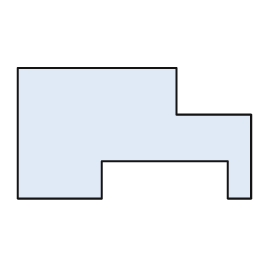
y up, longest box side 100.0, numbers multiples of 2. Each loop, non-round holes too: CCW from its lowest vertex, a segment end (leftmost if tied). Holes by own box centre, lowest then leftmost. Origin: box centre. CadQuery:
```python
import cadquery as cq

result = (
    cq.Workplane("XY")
    .moveTo(-50.0, -28.0)
    .lineTo(-14.0, -28.0)
    .lineTo(-14.0, -12.0)
    .lineTo(40.0, -12.0)
    .lineTo(40.0, -28.0)
    .lineTo(50.0, -28.0)
    .lineTo(50.0, 8.0)
    .lineTo(18.0, 8.0)
    .lineTo(18.0, 28.0)
    .lineTo(-50.0, 28.0)
    .close()
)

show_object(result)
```